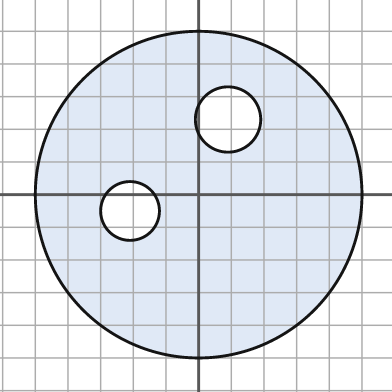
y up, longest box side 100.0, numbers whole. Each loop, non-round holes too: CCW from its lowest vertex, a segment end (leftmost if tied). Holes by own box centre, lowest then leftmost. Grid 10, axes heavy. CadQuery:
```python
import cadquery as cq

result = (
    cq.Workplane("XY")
    .moveTo(0.0, 0.0)
    .circle(50.0)
    .moveTo(-21.0, -5.0)
    .circle(9.0)
    .moveTo(9.0, 23.0)
    .circle(10.0)
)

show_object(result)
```